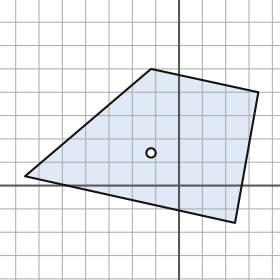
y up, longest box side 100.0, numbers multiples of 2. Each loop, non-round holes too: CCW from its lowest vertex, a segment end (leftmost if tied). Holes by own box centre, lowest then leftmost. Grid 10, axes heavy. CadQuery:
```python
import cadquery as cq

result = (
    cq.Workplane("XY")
    .moveTo(24.0, -16.0)
    .lineTo(34.0, 40.0)
    .lineTo(-12.0, 50.0)
    .lineTo(-66.0, 4.0)
    .close()
    .moveTo(-12.0, 14.0)
    .circle(2.0)
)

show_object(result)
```